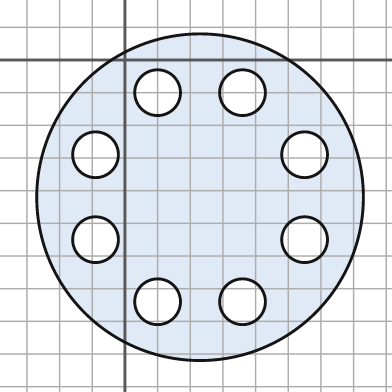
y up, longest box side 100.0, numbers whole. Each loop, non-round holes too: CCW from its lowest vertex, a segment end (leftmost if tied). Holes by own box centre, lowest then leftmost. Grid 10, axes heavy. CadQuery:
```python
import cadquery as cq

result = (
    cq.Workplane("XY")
    .moveTo(23.0, -42.0)
    .circle(50.0)
    .moveTo(10.0, -74.0)
    .circle(7.0)
    .moveTo(36.0, -74.0)
    .circle(7.0)
    .moveTo(-9.0, -55.0)
    .circle(7.0)
    .moveTo(55.0, -55.0)
    .circle(7.0)
    .moveTo(-9.0, -29.0)
    .circle(7.0)
    .moveTo(55.0, -29.0)
    .circle(7.0)
    .moveTo(10.0, -10.0)
    .circle(7.0)
    .moveTo(36.0, -10.0)
    .circle(7.0)
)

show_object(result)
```